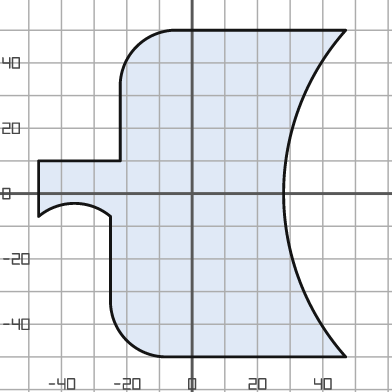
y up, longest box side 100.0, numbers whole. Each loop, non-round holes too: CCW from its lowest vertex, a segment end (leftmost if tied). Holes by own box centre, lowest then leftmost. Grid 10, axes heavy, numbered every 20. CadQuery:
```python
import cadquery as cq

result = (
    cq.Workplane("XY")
    .moveTo(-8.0, -50.0)
    .lineTo(47.0, -50.0)
    .threePointArc((28.0, 0.0), (47.0, 50.0))
    .lineTo(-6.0, 50.0)
    .threePointArc((-17.0, 45.0), (-22.0, 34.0))
    .lineTo(-22.0, 10.0)
    .lineTo(-47.0, 10.0)
    .lineTo(-47.0, -7.0)
    .threePointArc((-36.0, -3.0), (-25.0, -7.0))
    .lineTo(-25.0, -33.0)
    .threePointArc((-20.0, -45.0), (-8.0, -50.0))
    .close()
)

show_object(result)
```